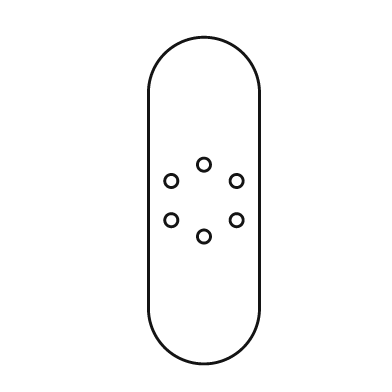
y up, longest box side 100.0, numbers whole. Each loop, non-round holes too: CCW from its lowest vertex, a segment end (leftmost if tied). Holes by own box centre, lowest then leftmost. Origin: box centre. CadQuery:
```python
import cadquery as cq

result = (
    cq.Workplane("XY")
    .moveTo(-17.0, -33.0)
    .threePointArc((0.0, -50.0), (17.0, -33.0))
    .lineTo(17.0, 33.0)
    .threePointArc((0.0, 50.0), (-17.0, 33.0))
    .close()
    .moveTo(0.0, -11.0)
    .circle(2.0)
    .moveTo(-10.0, -6.0)
    .circle(2.0)
    .moveTo(10.0, -6.0)
    .circle(2.0)
    .moveTo(-10.0, 6.0)
    .circle(2.0)
    .moveTo(10.0, 6.0)
    .circle(2.0)
    .moveTo(0.0, 11.0)
    .circle(2.0)
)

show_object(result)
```